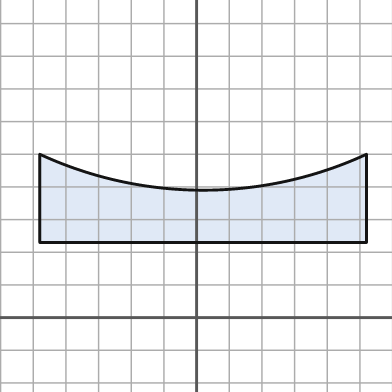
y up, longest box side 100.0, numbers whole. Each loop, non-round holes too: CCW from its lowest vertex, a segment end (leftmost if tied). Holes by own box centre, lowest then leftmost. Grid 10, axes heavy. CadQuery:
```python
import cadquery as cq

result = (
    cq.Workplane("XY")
    .moveTo(-48.0, 23.0)
    .lineTo(52.0, 23.0)
    .lineTo(52.0, 50.0)
    .threePointArc((2.0, 39.0), (-48.0, 50.0))
    .close()
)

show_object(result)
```